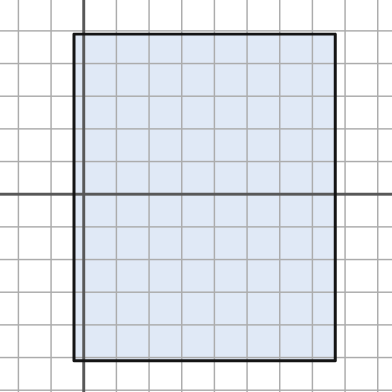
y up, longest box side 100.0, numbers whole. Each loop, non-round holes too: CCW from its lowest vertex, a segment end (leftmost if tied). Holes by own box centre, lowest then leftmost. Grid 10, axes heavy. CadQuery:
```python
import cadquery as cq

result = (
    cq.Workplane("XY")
    .moveTo(-3.0, -51.0)
    .lineTo(77.0, -51.0)
    .lineTo(77.0, 49.0)
    .lineTo(-3.0, 49.0)
    .close()
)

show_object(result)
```